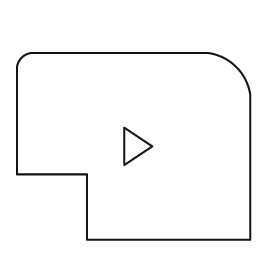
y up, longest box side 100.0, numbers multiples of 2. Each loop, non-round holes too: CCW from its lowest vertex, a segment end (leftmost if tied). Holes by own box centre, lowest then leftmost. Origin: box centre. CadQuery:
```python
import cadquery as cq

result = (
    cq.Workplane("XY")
    .moveTo(-20.0, -40.0)
    .lineTo(50.0, -40.0)
    .lineTo(50.0, 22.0)
    .threePointArc((44.0, 34.0), (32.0, 40.0))
    .lineTo(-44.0, 40.0)
    .threePointArc((-48.0, 38.0), (-50.0, 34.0))
    .lineTo(-50.0, -12.0)
    .lineTo(-20.0, -12.0)
    .close()
    .moveTo(-4.0, -8.0)
    .lineTo(8.0, 0.0)
    .lineTo(-4.0, 8.0)
    .close()
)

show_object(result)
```